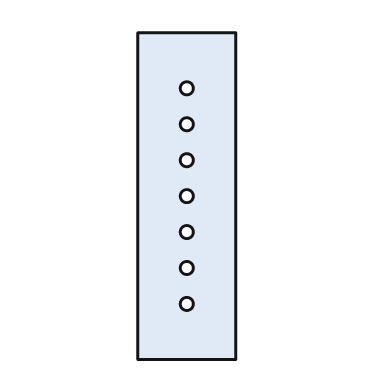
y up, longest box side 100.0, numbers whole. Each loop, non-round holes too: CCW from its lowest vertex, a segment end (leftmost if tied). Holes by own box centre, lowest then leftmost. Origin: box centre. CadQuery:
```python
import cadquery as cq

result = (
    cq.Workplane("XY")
    .moveTo(-15.0, -50.0)
    .lineTo(15.0, -50.0)
    .lineTo(15.0, 50.0)
    .lineTo(-15.0, 50.0)
    .close()
    .moveTo(0.0, -33.0)
    .circle(2.0)
    .moveTo(0.0, -22.0)
    .circle(2.0)
    .moveTo(0.0, -11.0)
    .circle(2.0)
    .moveTo(0.0, 0.0)
    .circle(2.0)
    .moveTo(0.0, 11.0)
    .circle(2.0)
    .moveTo(0.0, 22.0)
    .circle(2.0)
    .moveTo(0.0, 33.0)
    .circle(2.0)
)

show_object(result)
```